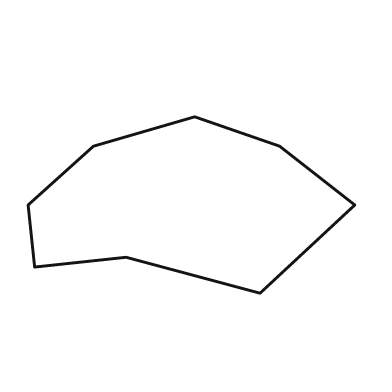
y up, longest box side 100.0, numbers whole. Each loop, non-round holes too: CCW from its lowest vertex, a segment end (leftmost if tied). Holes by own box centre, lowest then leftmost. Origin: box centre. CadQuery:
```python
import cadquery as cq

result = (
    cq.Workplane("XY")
    .moveTo(21.0, -27.0)
    .lineTo(50.0, 0.0)
    .lineTo(27.0, 18.0)
    .lineTo(1.0, 27.0)
    .lineTo(-30.0, 18.0)
    .lineTo(-50.0, 0.0)
    .lineTo(-48.0, -19.0)
    .lineTo(-20.0, -16.0)
    .close()
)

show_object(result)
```